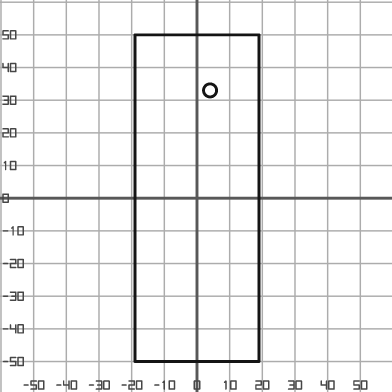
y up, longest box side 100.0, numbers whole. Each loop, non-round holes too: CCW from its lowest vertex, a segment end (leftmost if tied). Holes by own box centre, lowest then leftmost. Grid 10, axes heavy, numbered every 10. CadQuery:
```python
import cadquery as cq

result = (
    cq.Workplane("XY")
    .moveTo(-19.0, -50.0)
    .lineTo(19.0, -50.0)
    .lineTo(19.0, 50.0)
    .lineTo(-19.0, 50.0)
    .close()
    .moveTo(4.0, 33.0)
    .circle(2.0)
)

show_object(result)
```